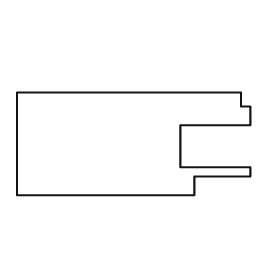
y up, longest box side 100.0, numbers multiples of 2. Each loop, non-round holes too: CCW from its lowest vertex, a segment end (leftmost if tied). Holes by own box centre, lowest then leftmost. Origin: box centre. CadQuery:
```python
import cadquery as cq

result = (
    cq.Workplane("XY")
    .moveTo(-50.0, -22.0)
    .lineTo(26.0, -22.0)
    .lineTo(26.0, -14.0)
    .lineTo(50.0, -14.0)
    .lineTo(50.0, -10.0)
    .lineTo(20.0, -10.0)
    .lineTo(20.0, 8.0)
    .lineTo(50.0, 8.0)
    .lineTo(50.0, 16.0)
    .lineTo(46.0, 16.0)
    .lineTo(46.0, 22.0)
    .lineTo(-50.0, 22.0)
    .close()
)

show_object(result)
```